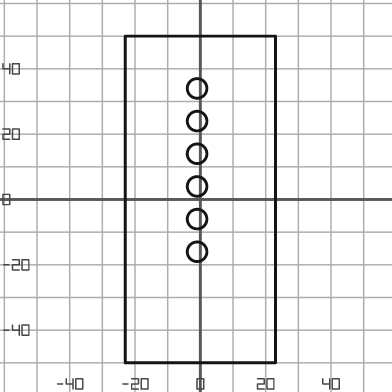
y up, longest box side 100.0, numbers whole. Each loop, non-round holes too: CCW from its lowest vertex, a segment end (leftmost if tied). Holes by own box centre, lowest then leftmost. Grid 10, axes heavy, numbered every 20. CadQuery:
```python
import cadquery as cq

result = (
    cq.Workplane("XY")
    .moveTo(-23.0, -50.0)
    .lineTo(23.0, -50.0)
    .lineTo(23.0, 50.0)
    .lineTo(-23.0, 50.0)
    .close()
    .moveTo(-1.0, -16.0)
    .circle(3.0)
    .moveTo(-1.0, -6.0)
    .circle(3.0)
    .moveTo(-1.0, 4.0)
    .circle(3.0)
    .moveTo(-1.0, 14.0)
    .circle(3.0)
    .moveTo(-1.0, 24.0)
    .circle(3.0)
    .moveTo(-1.0, 34.0)
    .circle(3.0)
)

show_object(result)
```